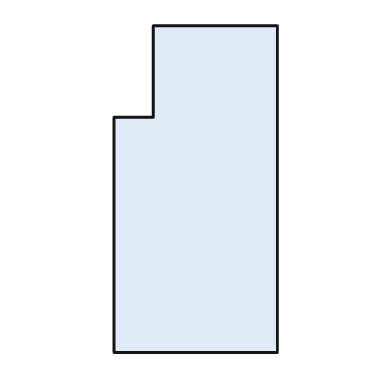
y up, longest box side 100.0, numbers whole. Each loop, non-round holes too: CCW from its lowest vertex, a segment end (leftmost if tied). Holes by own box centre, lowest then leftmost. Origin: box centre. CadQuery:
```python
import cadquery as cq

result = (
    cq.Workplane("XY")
    .moveTo(-25.0, -50.0)
    .lineTo(25.0, -50.0)
    .lineTo(25.0, 50.0)
    .lineTo(-13.0, 50.0)
    .lineTo(-13.0, 22.0)
    .lineTo(-25.0, 22.0)
    .close()
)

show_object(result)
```